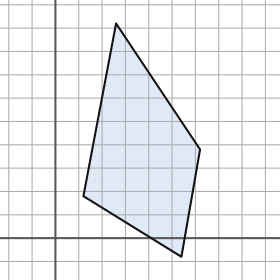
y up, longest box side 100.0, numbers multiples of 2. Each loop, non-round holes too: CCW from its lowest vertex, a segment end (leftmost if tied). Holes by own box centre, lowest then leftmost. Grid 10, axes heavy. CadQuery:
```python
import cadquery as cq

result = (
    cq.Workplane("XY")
    .moveTo(54.0, -8.0)
    .lineTo(62.0, 38.0)
    .lineTo(26.0, 92.0)
    .lineTo(12.0, 18.0)
    .close()
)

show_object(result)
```